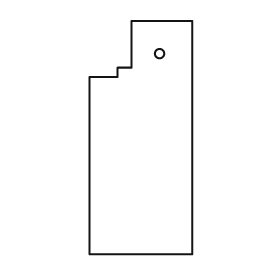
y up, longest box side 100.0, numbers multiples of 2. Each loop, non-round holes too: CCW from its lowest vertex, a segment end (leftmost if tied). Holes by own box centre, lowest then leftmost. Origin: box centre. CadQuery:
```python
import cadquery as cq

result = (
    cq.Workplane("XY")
    .moveTo(-22.0, -50.0)
    .lineTo(22.0, -50.0)
    .lineTo(22.0, 50.0)
    .lineTo(-4.0, 50.0)
    .lineTo(-4.0, 30.0)
    .lineTo(-10.0, 30.0)
    .lineTo(-10.0, 26.0)
    .lineTo(-22.0, 26.0)
    .close()
    .moveTo(8.0, 36.0)
    .circle(2.0)
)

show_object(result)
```